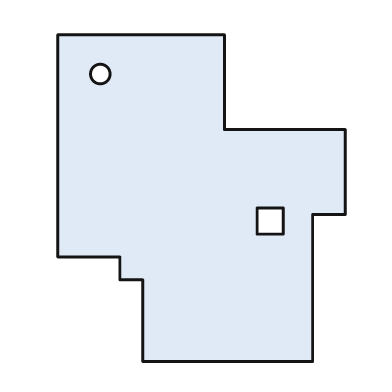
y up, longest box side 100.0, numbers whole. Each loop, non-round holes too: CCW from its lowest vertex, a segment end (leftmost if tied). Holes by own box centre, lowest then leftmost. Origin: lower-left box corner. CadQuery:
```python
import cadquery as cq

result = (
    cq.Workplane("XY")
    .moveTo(26.0, 0.0)
    .lineTo(78.0, 0.0)
    .lineTo(78.0, 45.0)
    .lineTo(88.0, 45.0)
    .lineTo(88.0, 71.0)
    .lineTo(51.0, 71.0)
    .lineTo(51.0, 100.0)
    .lineTo(0.0, 100.0)
    .lineTo(0.0, 32.0)
    .lineTo(19.0, 32.0)
    .lineTo(19.0, 25.0)
    .lineTo(26.0, 25.0)
    .close()
    .moveTo(61.0, 39.0)
    .lineTo(69.0, 39.0)
    .lineTo(69.0, 47.0)
    .lineTo(61.0, 47.0)
    .close()
    .moveTo(13.0, 88.0)
    .circle(3.0)
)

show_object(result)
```